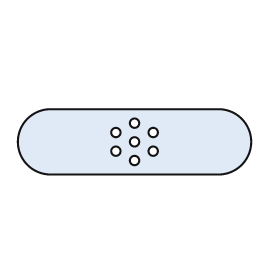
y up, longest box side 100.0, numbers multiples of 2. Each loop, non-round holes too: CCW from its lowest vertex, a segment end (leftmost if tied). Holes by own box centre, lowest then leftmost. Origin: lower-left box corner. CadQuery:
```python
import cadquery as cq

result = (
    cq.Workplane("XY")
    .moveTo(14.0, 0.0)
    .lineTo(86.0, 0.0)
    .threePointArc((100.0, 14.0), (86.0, 28.0))
    .lineTo(14.0, 28.0)
    .threePointArc((0.0, 14.0), (14.0, 0.0))
    .close()
    .moveTo(50.0, 6.0)
    .circle(2.0)
    .moveTo(42.0, 10.0)
    .circle(2.0)
    .moveTo(58.0, 10.0)
    .circle(2.0)
    .moveTo(50.0, 14.0)
    .circle(2.0)
    .moveTo(42.0, 18.0)
    .circle(2.0)
    .moveTo(58.0, 18.0)
    .circle(2.0)
    .moveTo(50.0, 22.0)
    .circle(2.0)
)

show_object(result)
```